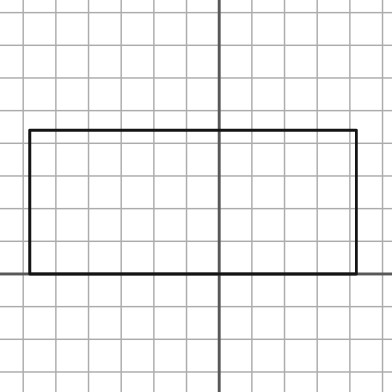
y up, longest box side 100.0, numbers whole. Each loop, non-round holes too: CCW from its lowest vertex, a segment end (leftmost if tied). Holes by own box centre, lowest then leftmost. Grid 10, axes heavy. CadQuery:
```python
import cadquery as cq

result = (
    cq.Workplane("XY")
    .moveTo(-58.0, 0.0)
    .lineTo(42.0, 0.0)
    .lineTo(42.0, 44.0)
    .lineTo(-58.0, 44.0)
    .close()
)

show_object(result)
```